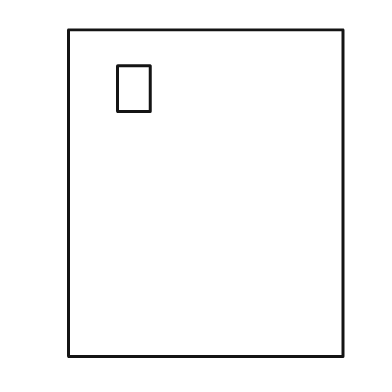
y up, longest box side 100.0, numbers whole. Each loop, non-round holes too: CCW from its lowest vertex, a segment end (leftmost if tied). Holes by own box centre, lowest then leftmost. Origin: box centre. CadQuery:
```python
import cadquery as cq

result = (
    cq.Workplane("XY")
    .moveTo(-42.0, -50.0)
    .lineTo(42.0, -50.0)
    .lineTo(42.0, 50.0)
    .lineTo(-42.0, 50.0)
    .close()
    .moveTo(-27.0, 25.0)
    .lineTo(-17.0, 25.0)
    .lineTo(-17.0, 39.0)
    .lineTo(-27.0, 39.0)
    .close()
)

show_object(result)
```